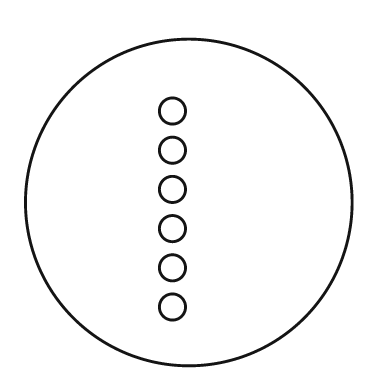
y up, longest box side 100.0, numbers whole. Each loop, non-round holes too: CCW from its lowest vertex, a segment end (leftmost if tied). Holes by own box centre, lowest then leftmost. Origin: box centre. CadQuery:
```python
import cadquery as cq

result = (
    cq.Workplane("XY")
    .moveTo(0.0, 0.0)
    .circle(50.0)
    .moveTo(-5.0, -32.0)
    .circle(4.0)
    .moveTo(-5.0, -20.0)
    .circle(4.0)
    .moveTo(-5.0, -8.0)
    .circle(4.0)
    .moveTo(-5.0, 4.0)
    .circle(4.0)
    .moveTo(-5.0, 16.0)
    .circle(4.0)
    .moveTo(-5.0, 28.0)
    .circle(4.0)
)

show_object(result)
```